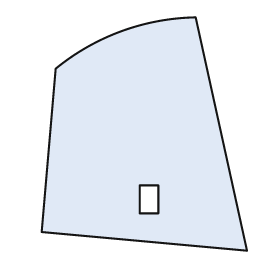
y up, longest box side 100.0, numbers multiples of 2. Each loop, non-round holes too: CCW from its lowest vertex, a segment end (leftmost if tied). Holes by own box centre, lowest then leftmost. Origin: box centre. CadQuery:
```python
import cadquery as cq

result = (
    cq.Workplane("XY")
    .moveTo(44.0, -50.0)
    .lineTo(22.0, 50.0)
    .threePointArc((-10.0, 44.0), (-38.0, 28.0))
    .lineTo(-44.0, -42.0)
    .close()
    .moveTo(-2.0, -34.0)
    .lineTo(6.0, -34.0)
    .lineTo(6.0, -22.0)
    .lineTo(-2.0, -22.0)
    .close()
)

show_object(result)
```